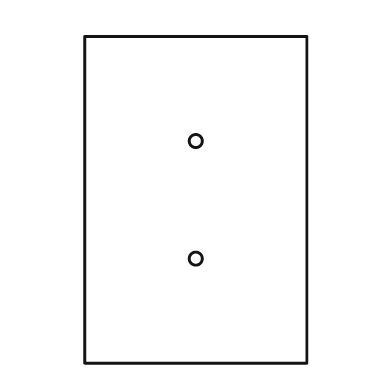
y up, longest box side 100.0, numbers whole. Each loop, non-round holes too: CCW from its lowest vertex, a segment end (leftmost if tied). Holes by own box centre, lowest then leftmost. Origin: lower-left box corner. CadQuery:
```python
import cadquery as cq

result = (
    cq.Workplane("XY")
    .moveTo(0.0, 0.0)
    .lineTo(68.0, 0.0)
    .lineTo(68.0, 100.0)
    .lineTo(0.0, 100.0)
    .close()
    .moveTo(34.0, 32.0)
    .circle(2.0)
    .moveTo(34.0, 68.0)
    .circle(2.0)
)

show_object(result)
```